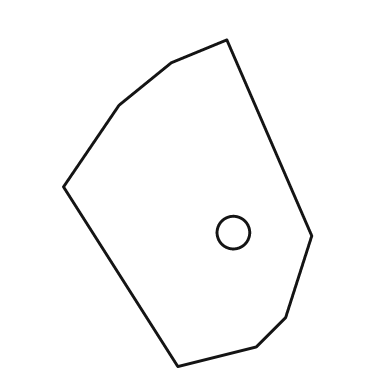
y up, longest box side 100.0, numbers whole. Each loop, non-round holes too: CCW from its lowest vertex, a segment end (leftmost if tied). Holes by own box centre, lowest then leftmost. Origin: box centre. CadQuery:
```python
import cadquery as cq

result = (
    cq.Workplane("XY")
    .moveTo(-3.0, -50.0)
    .lineTo(21.0, -44.0)
    .lineTo(30.0, -35.0)
    .lineTo(38.0, -10.0)
    .lineTo(12.0, 50.0)
    .lineTo(-5.0, 43.0)
    .lineTo(-21.0, 30.0)
    .lineTo(-38.0, 5.0)
    .close()
    .moveTo(14.0, -9.0)
    .circle(5.0)
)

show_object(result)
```